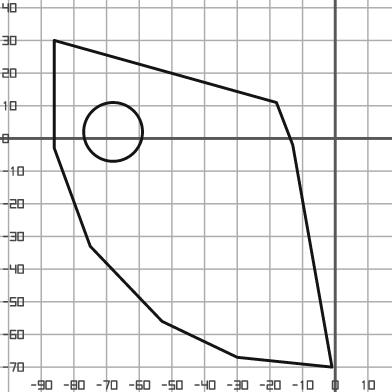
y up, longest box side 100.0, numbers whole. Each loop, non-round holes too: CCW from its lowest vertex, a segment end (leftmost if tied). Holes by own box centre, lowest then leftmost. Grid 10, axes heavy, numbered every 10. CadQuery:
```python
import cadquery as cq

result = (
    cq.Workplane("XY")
    .moveTo(-1.0, -70.0)
    .lineTo(-13.0, -2.0)
    .lineTo(-18.0, 11.0)
    .lineTo(-86.0, 30.0)
    .lineTo(-86.0, -3.0)
    .lineTo(-75.0, -33.0)
    .lineTo(-53.0, -56.0)
    .lineTo(-30.0, -67.0)
    .close()
    .moveTo(-68.0, 2.0)
    .circle(9.0)
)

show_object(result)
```